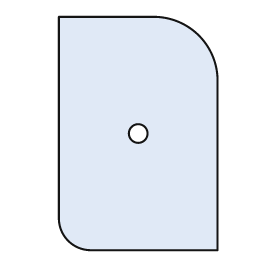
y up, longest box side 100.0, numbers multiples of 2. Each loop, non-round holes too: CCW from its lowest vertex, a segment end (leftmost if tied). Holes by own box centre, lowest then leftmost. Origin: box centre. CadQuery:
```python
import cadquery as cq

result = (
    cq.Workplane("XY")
    .moveTo(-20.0, -50.0)
    .lineTo(34.0, -50.0)
    .lineTo(34.0, 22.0)
    .threePointArc((26.0, 42.0), (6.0, 50.0))
    .lineTo(-34.0, 50.0)
    .lineTo(-34.0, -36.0)
    .threePointArc((-30.0, -46.0), (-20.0, -50.0))
    .close()
    .moveTo(0.0, 0.0)
    .circle(4.0)
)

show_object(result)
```